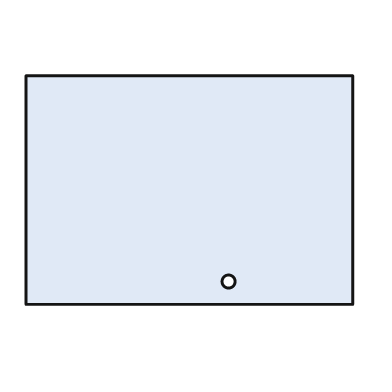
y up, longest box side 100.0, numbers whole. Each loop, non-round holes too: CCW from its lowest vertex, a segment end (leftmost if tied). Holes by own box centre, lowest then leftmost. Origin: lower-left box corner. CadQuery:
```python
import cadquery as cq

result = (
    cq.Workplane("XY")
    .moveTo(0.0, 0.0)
    .lineTo(100.0, 0.0)
    .lineTo(100.0, 70.0)
    .lineTo(0.0, 70.0)
    .close()
    .moveTo(62.0, 7.0)
    .circle(2.0)
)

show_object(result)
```